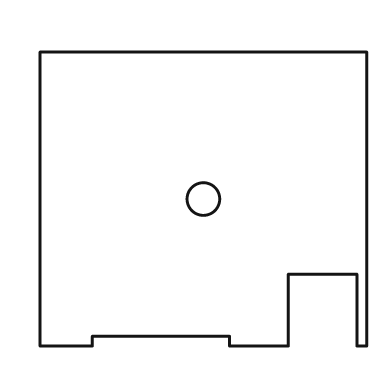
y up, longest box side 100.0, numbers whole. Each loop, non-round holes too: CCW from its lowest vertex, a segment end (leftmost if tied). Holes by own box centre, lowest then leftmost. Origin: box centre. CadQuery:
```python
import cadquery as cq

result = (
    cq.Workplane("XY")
    .moveTo(-50.0, -45.0)
    .lineTo(-34.0, -45.0)
    .lineTo(-34.0, -42.0)
    .lineTo(8.0, -42.0)
    .lineTo(8.0, -45.0)
    .lineTo(26.0, -45.0)
    .lineTo(26.0, -23.0)
    .lineTo(47.0, -23.0)
    .lineTo(47.0, -45.0)
    .lineTo(50.0, -45.0)
    .lineTo(50.0, 45.0)
    .lineTo(-50.0, 45.0)
    .close()
    .moveTo(0.0, 0.0)
    .circle(5.0)
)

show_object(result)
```